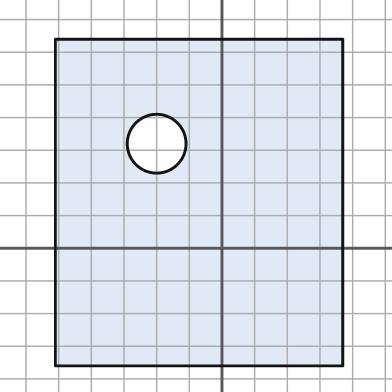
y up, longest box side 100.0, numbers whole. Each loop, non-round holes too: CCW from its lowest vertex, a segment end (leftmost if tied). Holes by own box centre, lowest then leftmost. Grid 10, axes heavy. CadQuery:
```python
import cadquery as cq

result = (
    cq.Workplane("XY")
    .moveTo(-51.0, -36.0)
    .lineTo(37.0, -36.0)
    .lineTo(37.0, 64.0)
    .lineTo(-51.0, 64.0)
    .close()
    .moveTo(-20.0, 32.0)
    .circle(9.0)
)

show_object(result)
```